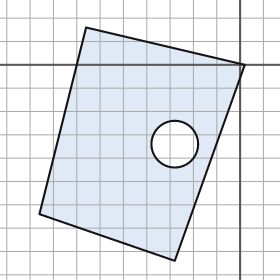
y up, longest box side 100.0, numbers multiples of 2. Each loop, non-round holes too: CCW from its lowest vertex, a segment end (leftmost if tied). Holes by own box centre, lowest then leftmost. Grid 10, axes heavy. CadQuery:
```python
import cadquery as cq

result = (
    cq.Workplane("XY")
    .moveTo(-28.0, -84.0)
    .lineTo(2.0, 0.0)
    .lineTo(-66.0, 16.0)
    .lineTo(-86.0, -64.0)
    .close()
    .moveTo(-28.0, -34.0)
    .circle(10.0)
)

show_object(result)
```